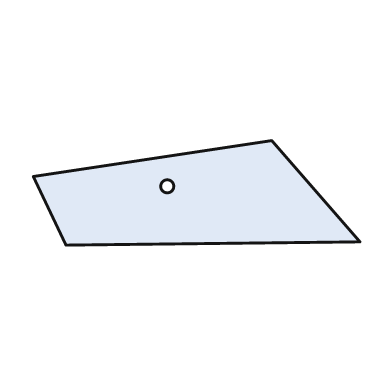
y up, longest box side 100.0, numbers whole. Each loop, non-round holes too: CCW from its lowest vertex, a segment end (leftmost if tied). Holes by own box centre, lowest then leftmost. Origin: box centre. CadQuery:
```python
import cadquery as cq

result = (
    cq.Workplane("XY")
    .moveTo(-40.0, -16.0)
    .lineTo(50.0, -15.0)
    .lineTo(23.0, 16.0)
    .lineTo(-50.0, 5.0)
    .close()
    .moveTo(-9.0, 2.0)
    .circle(2.0)
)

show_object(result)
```